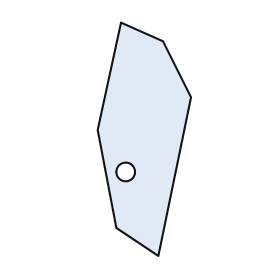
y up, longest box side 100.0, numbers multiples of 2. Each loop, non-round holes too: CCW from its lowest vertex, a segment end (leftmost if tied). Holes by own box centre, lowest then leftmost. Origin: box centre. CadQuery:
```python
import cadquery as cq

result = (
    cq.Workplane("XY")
    .moveTo(6.0, -50.0)
    .lineTo(20.0, 18.0)
    .lineTo(8.0, 42.0)
    .lineTo(-10.0, 50.0)
    .lineTo(-20.0, 4.0)
    .lineTo(-12.0, -38.0)
    .close()
    .moveTo(-8.0, -14.0)
    .circle(4.0)
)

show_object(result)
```